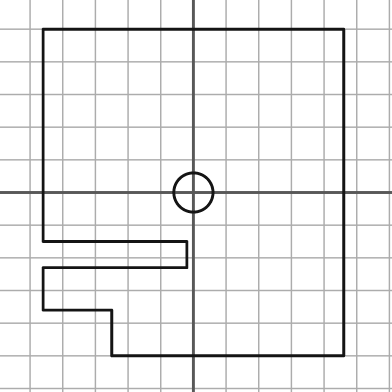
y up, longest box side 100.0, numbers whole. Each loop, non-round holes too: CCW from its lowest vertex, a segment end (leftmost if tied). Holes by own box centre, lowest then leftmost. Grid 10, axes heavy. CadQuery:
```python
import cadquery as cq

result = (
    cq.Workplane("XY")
    .moveTo(-25.0, -50.0)
    .lineTo(46.0, -50.0)
    .lineTo(46.0, 50.0)
    .lineTo(-46.0, 50.0)
    .lineTo(-46.0, -15.0)
    .lineTo(-2.0, -15.0)
    .lineTo(-2.0, -23.0)
    .lineTo(-46.0, -23.0)
    .lineTo(-46.0, -36.0)
    .lineTo(-25.0, -36.0)
    .close()
    .moveTo(0.0, 0.0)
    .circle(6.0)
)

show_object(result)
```